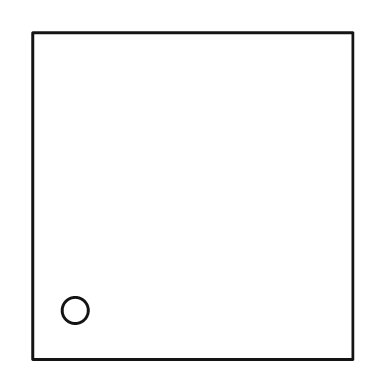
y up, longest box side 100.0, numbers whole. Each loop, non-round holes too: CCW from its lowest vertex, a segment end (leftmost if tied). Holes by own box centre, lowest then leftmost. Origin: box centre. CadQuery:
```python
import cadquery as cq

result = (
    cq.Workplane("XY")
    .moveTo(-49.0, -50.0)
    .lineTo(49.0, -50.0)
    .lineTo(49.0, 50.0)
    .lineTo(-49.0, 50.0)
    .close()
    .moveTo(-36.0, -35.0)
    .circle(4.0)
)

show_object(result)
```